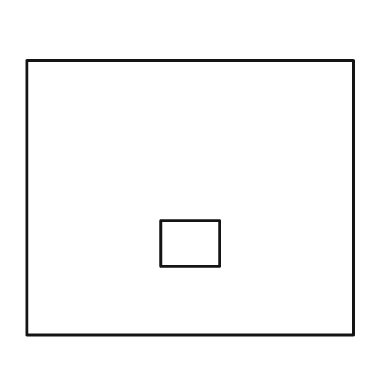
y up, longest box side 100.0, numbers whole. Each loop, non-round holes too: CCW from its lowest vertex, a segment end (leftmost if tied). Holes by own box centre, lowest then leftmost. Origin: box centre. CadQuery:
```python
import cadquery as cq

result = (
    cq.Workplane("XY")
    .moveTo(-50.0, -42.0)
    .lineTo(50.0, -42.0)
    .lineTo(50.0, 42.0)
    .lineTo(-50.0, 42.0)
    .close()
    .moveTo(-9.0, -21.0)
    .lineTo(9.0, -21.0)
    .lineTo(9.0, -7.0)
    .lineTo(-9.0, -7.0)
    .close()
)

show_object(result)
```